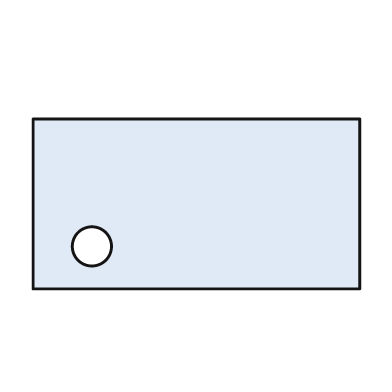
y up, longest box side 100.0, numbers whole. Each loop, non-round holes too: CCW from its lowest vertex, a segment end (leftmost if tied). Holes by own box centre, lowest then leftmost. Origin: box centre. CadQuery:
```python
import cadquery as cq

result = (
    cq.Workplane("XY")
    .moveTo(-50.0, -26.0)
    .lineTo(50.0, -26.0)
    .lineTo(50.0, 26.0)
    .lineTo(-50.0, 26.0)
    .close()
    .moveTo(-32.0, -13.0)
    .circle(6.0)
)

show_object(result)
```